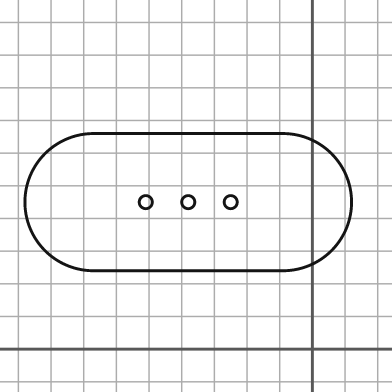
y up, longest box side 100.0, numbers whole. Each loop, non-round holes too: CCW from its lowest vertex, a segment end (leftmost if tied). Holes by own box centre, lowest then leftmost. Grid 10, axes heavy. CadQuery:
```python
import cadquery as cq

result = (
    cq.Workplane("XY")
    .moveTo(-67.0, 24.0)
    .lineTo(-9.0, 24.0)
    .threePointArc((12.0, 45.0), (-9.0, 66.0))
    .lineTo(-67.0, 66.0)
    .threePointArc((-88.0, 45.0), (-67.0, 24.0))
    .close()
    .moveTo(-51.0, 45.0)
    .circle(2.0)
    .moveTo(-38.0, 45.0)
    .circle(2.0)
    .moveTo(-25.0, 45.0)
    .circle(2.0)
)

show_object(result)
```